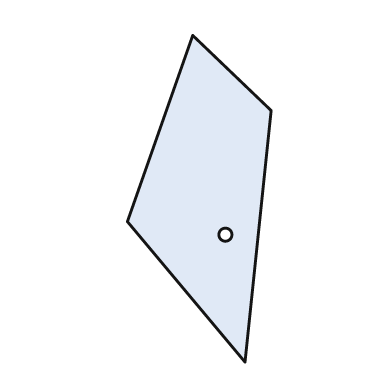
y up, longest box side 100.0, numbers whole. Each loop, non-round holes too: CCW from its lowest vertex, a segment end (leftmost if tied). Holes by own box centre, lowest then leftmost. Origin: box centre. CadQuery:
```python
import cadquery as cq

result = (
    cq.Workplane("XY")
    .moveTo(14.0, -50.0)
    .lineTo(22.0, 27.0)
    .lineTo(-2.0, 50.0)
    .lineTo(-22.0, -7.0)
    .close()
    .moveTo(8.0, -11.0)
    .circle(2.0)
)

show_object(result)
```